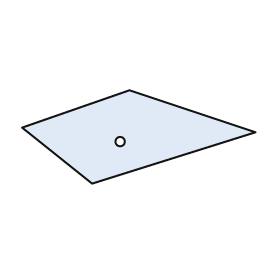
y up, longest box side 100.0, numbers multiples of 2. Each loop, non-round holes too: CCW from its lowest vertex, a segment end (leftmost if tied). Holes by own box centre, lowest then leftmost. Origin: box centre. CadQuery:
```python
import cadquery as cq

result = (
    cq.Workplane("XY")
    .moveTo(-20.0, -20.0)
    .lineTo(50.0, 2.0)
    .lineTo(-4.0, 20.0)
    .lineTo(-50.0, 4.0)
    .close()
    .moveTo(-8.0, -2.0)
    .circle(2.0)
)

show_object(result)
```